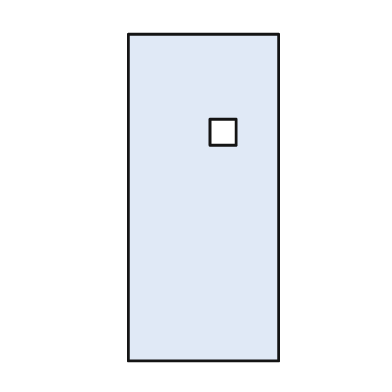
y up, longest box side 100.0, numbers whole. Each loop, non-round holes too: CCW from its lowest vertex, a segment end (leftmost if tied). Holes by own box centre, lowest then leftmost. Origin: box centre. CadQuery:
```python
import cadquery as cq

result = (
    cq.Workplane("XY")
    .moveTo(-23.0, -50.0)
    .lineTo(23.0, -50.0)
    .lineTo(23.0, 50.0)
    .lineTo(-23.0, 50.0)
    .close()
    .moveTo(2.0, 16.0)
    .lineTo(10.0, 16.0)
    .lineTo(10.0, 24.0)
    .lineTo(2.0, 24.0)
    .close()
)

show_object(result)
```